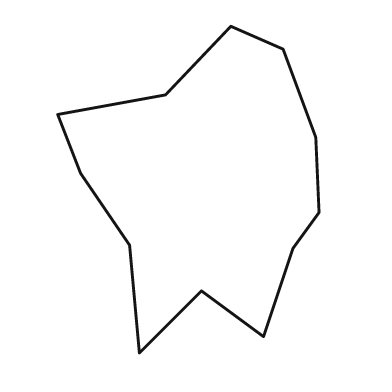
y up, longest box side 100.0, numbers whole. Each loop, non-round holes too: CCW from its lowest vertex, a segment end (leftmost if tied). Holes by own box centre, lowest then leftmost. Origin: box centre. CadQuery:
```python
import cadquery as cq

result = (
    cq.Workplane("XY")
    .moveTo(-15.0, -50.0)
    .lineTo(4.0, -31.0)
    .lineTo(23.0, -45.0)
    .lineTo(32.0, -18.0)
    .lineTo(40.0, -7.0)
    .lineTo(39.0, 16.0)
    .lineTo(29.0, 43.0)
    .lineTo(13.0, 50.0)
    .lineTo(-7.0, 29.0)
    .lineTo(-40.0, 23.0)
    .lineTo(-33.0, 5.0)
    .lineTo(-18.0, -17.0)
    .close()
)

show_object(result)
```